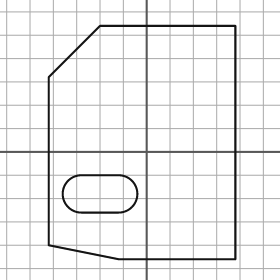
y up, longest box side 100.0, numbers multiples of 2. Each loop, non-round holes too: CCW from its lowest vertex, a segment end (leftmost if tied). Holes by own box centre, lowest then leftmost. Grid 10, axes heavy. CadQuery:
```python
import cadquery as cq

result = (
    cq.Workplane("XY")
    .moveTo(-12.0, -46.0)
    .lineTo(38.0, -46.0)
    .lineTo(38.0, 54.0)
    .lineTo(-20.0, 54.0)
    .lineTo(-42.0, 32.0)
    .lineTo(-42.0, -40.0)
    .close()
    .moveTo(-28.0, -26.0)
    .lineTo(-12.0, -26.0)
    .threePointArc((-4.0, -18.0), (-12.0, -10.0))
    .lineTo(-28.0, -10.0)
    .threePointArc((-36.0, -18.0), (-28.0, -26.0))
    .close()
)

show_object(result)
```